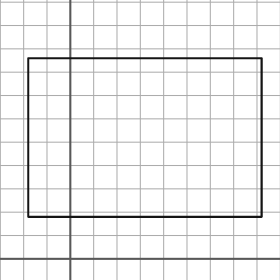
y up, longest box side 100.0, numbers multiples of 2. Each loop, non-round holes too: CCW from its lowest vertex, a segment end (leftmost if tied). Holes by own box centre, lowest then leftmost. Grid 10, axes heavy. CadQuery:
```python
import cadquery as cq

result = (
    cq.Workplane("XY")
    .moveTo(-18.0, 18.0)
    .lineTo(82.0, 18.0)
    .lineTo(82.0, 86.0)
    .lineTo(-18.0, 86.0)
    .close()
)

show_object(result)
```